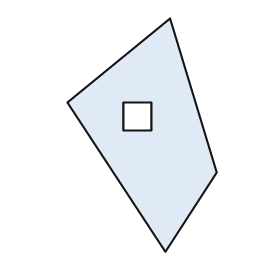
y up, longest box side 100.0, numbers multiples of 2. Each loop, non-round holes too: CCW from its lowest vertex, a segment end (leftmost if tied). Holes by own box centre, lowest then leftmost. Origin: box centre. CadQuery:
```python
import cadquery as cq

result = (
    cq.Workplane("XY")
    .moveTo(10.0, -50.0)
    .lineTo(32.0, -16.0)
    .lineTo(12.0, 50.0)
    .lineTo(-32.0, 14.0)
    .close()
    .moveTo(-8.0, 2.0)
    .lineTo(4.0, 2.0)
    .lineTo(4.0, 14.0)
    .lineTo(-8.0, 14.0)
    .close()
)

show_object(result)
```